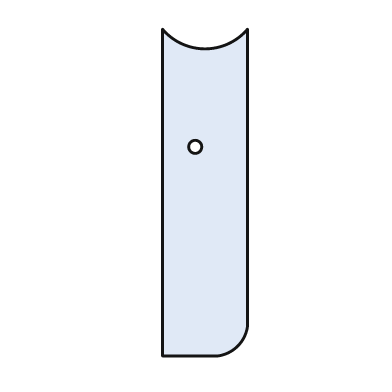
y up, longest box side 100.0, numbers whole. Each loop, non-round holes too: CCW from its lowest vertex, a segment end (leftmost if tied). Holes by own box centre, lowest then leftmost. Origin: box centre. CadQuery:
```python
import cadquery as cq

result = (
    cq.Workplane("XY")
    .moveTo(-13.0, -50.0)
    .lineTo(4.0, -50.0)
    .threePointArc((10.0, -47.0), (13.0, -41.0))
    .lineTo(13.0, 50.0)
    .threePointArc((0.0, 44.0), (-13.0, 50.0))
    .close()
    .moveTo(-3.0, 14.0)
    .circle(2.0)
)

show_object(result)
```